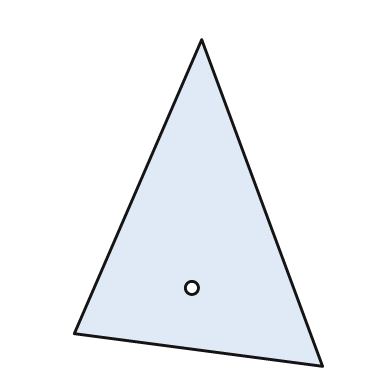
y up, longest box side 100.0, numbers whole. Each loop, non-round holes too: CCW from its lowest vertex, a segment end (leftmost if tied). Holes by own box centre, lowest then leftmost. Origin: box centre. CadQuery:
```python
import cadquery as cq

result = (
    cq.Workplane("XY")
    .moveTo(38.0, -50.0)
    .lineTo(1.0, 50.0)
    .lineTo(-38.0, -40.0)
    .close()
    .moveTo(-2.0, -26.0)
    .circle(2.0)
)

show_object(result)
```